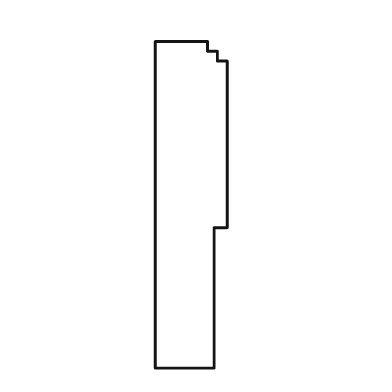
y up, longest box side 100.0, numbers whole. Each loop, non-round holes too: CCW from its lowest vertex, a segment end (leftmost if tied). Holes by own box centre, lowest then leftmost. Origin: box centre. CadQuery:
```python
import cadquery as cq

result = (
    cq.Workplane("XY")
    .moveTo(-11.0, -50.0)
    .lineTo(7.0, -50.0)
    .lineTo(7.0, -7.0)
    .lineTo(11.0, -7.0)
    .lineTo(11.0, 44.0)
    .lineTo(8.0, 44.0)
    .lineTo(8.0, 47.0)
    .lineTo(5.0, 47.0)
    .lineTo(5.0, 50.0)
    .lineTo(-11.0, 50.0)
    .close()
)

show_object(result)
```